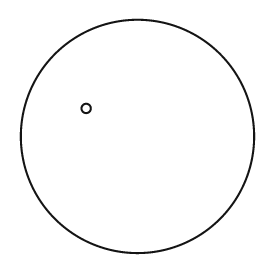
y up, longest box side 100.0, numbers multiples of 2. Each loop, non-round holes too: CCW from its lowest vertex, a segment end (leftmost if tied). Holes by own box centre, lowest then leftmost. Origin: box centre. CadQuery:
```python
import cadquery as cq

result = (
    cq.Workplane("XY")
    .moveTo(0.0, 0.0)
    .circle(50.0)
    .moveTo(-22.0, 12.0)
    .circle(2.0)
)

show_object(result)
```